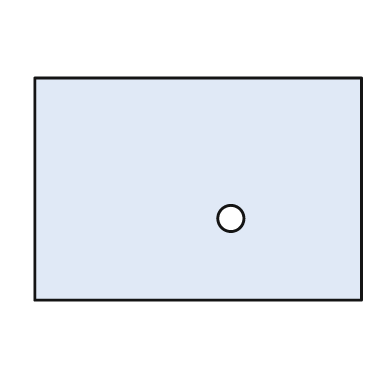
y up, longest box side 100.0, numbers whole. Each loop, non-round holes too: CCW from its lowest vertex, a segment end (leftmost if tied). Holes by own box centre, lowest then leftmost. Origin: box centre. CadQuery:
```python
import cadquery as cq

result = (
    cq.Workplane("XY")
    .moveTo(-50.0, -34.0)
    .lineTo(50.0, -34.0)
    .lineTo(50.0, 34.0)
    .lineTo(-50.0, 34.0)
    .close()
    .moveTo(10.0, -9.0)
    .circle(4.0)
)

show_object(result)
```